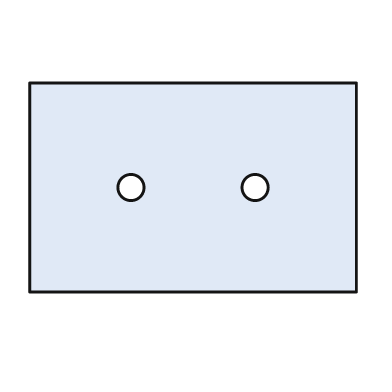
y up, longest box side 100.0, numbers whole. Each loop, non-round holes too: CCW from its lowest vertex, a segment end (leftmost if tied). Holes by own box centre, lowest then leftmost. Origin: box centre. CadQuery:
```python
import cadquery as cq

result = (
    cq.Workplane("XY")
    .moveTo(-50.0, -32.0)
    .lineTo(50.0, -32.0)
    .lineTo(50.0, 32.0)
    .lineTo(-50.0, 32.0)
    .close()
    .moveTo(-19.0, 0.0)
    .circle(4.0)
    .moveTo(19.0, 0.0)
    .circle(4.0)
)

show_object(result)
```